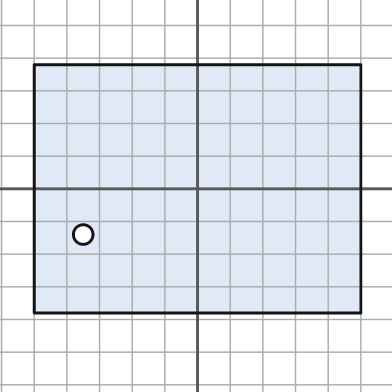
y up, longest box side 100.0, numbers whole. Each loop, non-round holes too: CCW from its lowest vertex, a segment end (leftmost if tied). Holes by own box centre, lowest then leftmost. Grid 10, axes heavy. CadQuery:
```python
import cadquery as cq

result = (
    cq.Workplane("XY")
    .moveTo(-50.0, -38.0)
    .lineTo(50.0, -38.0)
    .lineTo(50.0, 38.0)
    .lineTo(-50.0, 38.0)
    .close()
    .moveTo(-35.0, -14.0)
    .circle(3.0)
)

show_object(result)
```